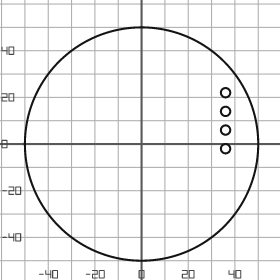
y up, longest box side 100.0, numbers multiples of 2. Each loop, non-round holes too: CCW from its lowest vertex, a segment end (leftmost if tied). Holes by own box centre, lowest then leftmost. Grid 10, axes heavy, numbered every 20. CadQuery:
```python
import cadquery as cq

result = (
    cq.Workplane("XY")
    .moveTo(0.0, 0.0)
    .circle(50.0)
    .moveTo(36.0, -2.0)
    .circle(2.0)
    .moveTo(36.0, 6.0)
    .circle(2.0)
    .moveTo(36.0, 14.0)
    .circle(2.0)
    .moveTo(36.0, 22.0)
    .circle(2.0)
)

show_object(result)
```